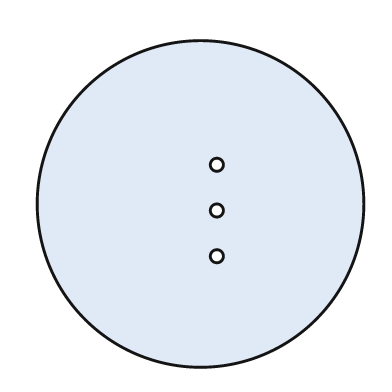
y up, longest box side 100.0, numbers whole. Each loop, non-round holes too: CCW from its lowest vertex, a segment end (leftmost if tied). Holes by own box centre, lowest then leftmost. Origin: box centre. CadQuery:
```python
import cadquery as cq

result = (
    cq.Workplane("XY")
    .moveTo(0.0, 0.0)
    .circle(50.0)
    .moveTo(5.0, -16.0)
    .circle(2.0)
    .moveTo(5.0, -2.0)
    .circle(2.0)
    .moveTo(5.0, 12.0)
    .circle(2.0)
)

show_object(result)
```